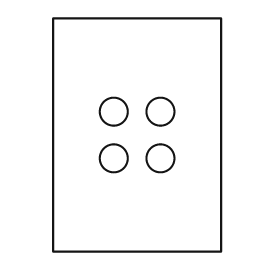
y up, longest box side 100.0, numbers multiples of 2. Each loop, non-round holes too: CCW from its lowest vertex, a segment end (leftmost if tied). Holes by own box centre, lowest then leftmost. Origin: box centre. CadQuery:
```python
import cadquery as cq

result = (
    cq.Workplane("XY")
    .moveTo(-36.0, -50.0)
    .lineTo(36.0, -50.0)
    .lineTo(36.0, 50.0)
    .lineTo(-36.0, 50.0)
    .close()
    .moveTo(-10.0, -10.0)
    .circle(6.0)
    .moveTo(10.0, -10.0)
    .circle(6.0)
    .moveTo(-10.0, 10.0)
    .circle(6.0)
    .moveTo(10.0, 10.0)
    .circle(6.0)
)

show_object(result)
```